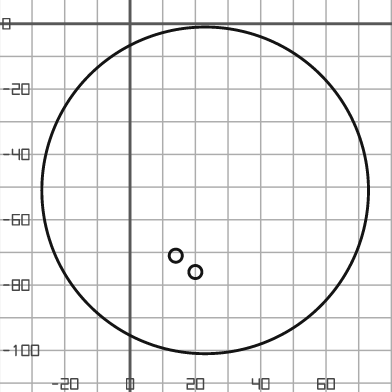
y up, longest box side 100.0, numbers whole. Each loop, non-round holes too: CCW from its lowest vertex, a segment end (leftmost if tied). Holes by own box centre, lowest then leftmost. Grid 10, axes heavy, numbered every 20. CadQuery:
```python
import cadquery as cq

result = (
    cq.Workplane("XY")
    .moveTo(23.0, -51.0)
    .circle(50.0)
    .moveTo(20.0, -76.0)
    .circle(2.0)
    .moveTo(14.0, -71.0)
    .circle(2.0)
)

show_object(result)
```